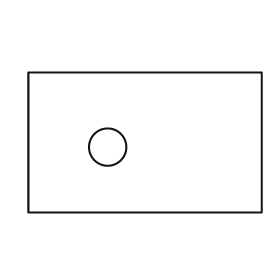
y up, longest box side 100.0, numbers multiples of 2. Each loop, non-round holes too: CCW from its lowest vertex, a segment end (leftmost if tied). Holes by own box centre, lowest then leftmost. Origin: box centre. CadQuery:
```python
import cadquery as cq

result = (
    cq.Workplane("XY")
    .moveTo(-50.0, -30.0)
    .lineTo(50.0, -30.0)
    .lineTo(50.0, 30.0)
    .lineTo(-50.0, 30.0)
    .close()
    .moveTo(-16.0, -2.0)
    .circle(8.0)
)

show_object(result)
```